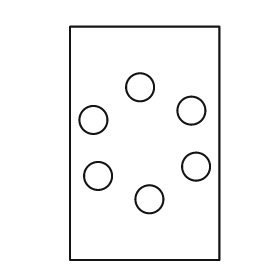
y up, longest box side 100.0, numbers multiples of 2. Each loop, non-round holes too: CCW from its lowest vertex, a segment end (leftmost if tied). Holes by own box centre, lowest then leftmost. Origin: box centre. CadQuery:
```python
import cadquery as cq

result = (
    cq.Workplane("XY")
    .moveTo(-32.0, -50.0)
    .lineTo(32.0, -50.0)
    .lineTo(32.0, 50.0)
    .lineTo(-32.0, 50.0)
    .close()
    .moveTo(2.0, -24.0)
    .circle(6.0)
    .moveTo(-20.0, -14.0)
    .circle(6.0)
    .moveTo(22.0, -10.0)
    .circle(6.0)
    .moveTo(-22.0, 10.0)
    .circle(6.0)
    .moveTo(20.0, 14.0)
    .circle(6.0)
    .moveTo(-2.0, 24.0)
    .circle(6.0)
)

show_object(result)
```